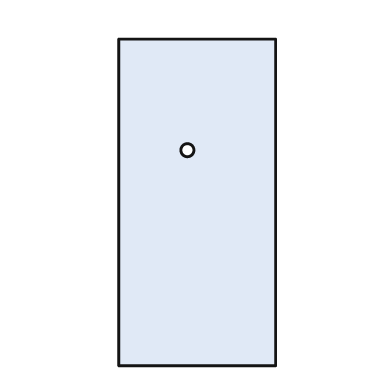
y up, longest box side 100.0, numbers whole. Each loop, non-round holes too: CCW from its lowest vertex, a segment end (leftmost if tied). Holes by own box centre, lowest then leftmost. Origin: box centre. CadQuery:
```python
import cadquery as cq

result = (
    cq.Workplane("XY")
    .moveTo(-24.0, -50.0)
    .lineTo(24.0, -50.0)
    .lineTo(24.0, 50.0)
    .lineTo(-24.0, 50.0)
    .close()
    .moveTo(-3.0, 16.0)
    .circle(2.0)
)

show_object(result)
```